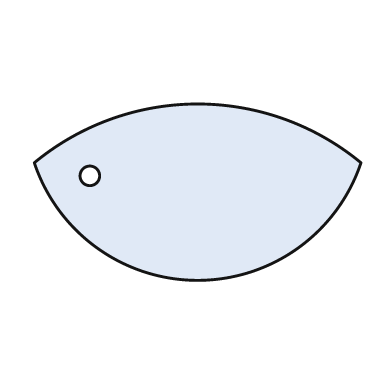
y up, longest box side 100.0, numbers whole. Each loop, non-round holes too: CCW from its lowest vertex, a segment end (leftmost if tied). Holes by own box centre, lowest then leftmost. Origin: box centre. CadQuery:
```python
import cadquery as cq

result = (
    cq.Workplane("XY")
    .moveTo(-50.0, 9.0)
    .threePointArc((0.0, -27.0), (50.0, 9.0))
    .threePointArc((0.0, 27.0), (-50.0, 9.0))
    .close()
    .moveTo(-33.0, 5.0)
    .circle(3.0)
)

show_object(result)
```